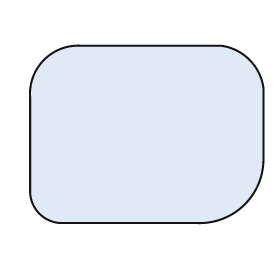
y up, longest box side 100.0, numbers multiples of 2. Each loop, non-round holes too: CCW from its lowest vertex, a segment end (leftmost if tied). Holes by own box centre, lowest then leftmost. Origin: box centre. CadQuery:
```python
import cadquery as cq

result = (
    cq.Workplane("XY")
    .moveTo(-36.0, -38.0)
    .lineTo(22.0, -38.0)
    .threePointArc((42.0, -30.0), (50.0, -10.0))
    .lineTo(50.0, 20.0)
    .threePointArc((44.0, 32.0), (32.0, 38.0))
    .lineTo(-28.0, 38.0)
    .threePointArc((-44.0, 32.0), (-50.0, 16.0))
    .lineTo(-50.0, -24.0)
    .threePointArc((-46.0, -34.0), (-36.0, -38.0))
    .close()
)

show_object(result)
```